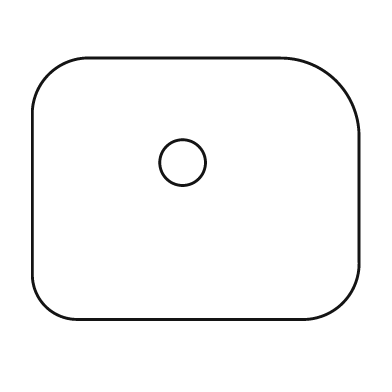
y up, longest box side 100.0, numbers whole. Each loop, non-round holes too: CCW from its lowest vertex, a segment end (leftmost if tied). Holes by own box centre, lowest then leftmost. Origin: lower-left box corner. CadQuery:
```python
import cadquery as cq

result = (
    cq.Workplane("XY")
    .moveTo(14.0, 0.0)
    .lineTo(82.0, 0.0)
    .threePointArc((95.0, 5.0), (100.0, 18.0))
    .lineTo(100.0, 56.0)
    .threePointArc((93.0, 73.0), (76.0, 80.0))
    .lineTo(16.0, 80.0)
    .threePointArc((5.0, 75.0), (0.0, 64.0))
    .lineTo(0.0, 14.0)
    .threePointArc((4.0, 4.0), (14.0, 0.0))
    .close()
    .moveTo(46.0, 48.0)
    .circle(7.0)
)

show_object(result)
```